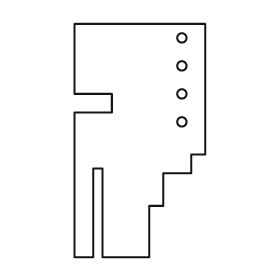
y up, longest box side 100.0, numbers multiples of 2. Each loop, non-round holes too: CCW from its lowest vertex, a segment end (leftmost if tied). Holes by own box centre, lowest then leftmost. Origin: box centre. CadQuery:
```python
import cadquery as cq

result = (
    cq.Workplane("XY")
    .moveTo(-28.0, -50.0)
    .lineTo(-20.0, -50.0)
    .lineTo(-20.0, -12.0)
    .lineTo(-16.0, -12.0)
    .lineTo(-16.0, -50.0)
    .lineTo(4.0, -50.0)
    .lineTo(4.0, -28.0)
    .lineTo(10.0, -28.0)
    .lineTo(10.0, -14.0)
    .lineTo(22.0, -14.0)
    .lineTo(22.0, -6.0)
    .lineTo(28.0, -6.0)
    .lineTo(28.0, 50.0)
    .lineTo(-28.0, 50.0)
    .lineTo(-28.0, 20.0)
    .lineTo(-12.0, 20.0)
    .lineTo(-12.0, 12.0)
    .lineTo(-28.0, 12.0)
    .close()
    .moveTo(18.0, 8.0)
    .circle(2.0)
    .moveTo(18.0, 20.0)
    .circle(2.0)
    .moveTo(18.0, 32.0)
    .circle(2.0)
    .moveTo(18.0, 44.0)
    .circle(2.0)
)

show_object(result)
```